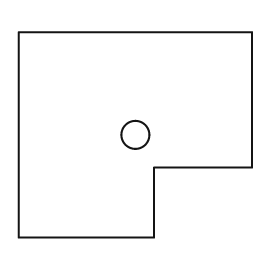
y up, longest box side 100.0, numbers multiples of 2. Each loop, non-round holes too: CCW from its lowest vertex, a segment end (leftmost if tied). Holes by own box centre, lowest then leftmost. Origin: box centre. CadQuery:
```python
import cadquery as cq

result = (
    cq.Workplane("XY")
    .moveTo(-50.0, -44.0)
    .lineTo(8.0, -44.0)
    .lineTo(8.0, -14.0)
    .lineTo(50.0, -14.0)
    .lineTo(50.0, 44.0)
    .lineTo(-50.0, 44.0)
    .close()
    .moveTo(0.0, 0.0)
    .circle(6.0)
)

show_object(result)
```